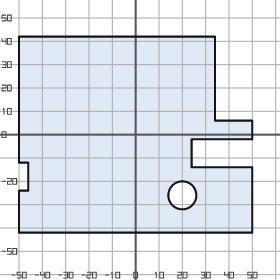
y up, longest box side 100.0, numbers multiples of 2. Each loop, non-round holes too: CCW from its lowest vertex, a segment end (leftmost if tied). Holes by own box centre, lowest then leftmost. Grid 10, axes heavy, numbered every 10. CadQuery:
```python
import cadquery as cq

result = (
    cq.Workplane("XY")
    .moveTo(-50.0, -42.0)
    .lineTo(50.0, -42.0)
    .lineTo(50.0, -14.0)
    .lineTo(24.0, -14.0)
    .lineTo(24.0, -2.0)
    .lineTo(50.0, -2.0)
    .lineTo(50.0, 6.0)
    .lineTo(34.0, 6.0)
    .lineTo(34.0, 42.0)
    .lineTo(-50.0, 42.0)
    .lineTo(-50.0, -12.0)
    .lineTo(-46.0, -12.0)
    .lineTo(-46.0, -24.0)
    .lineTo(-50.0, -24.0)
    .close()
    .moveTo(20.0, -26.0)
    .circle(6.0)
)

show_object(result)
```